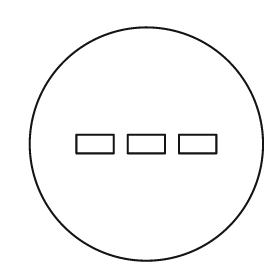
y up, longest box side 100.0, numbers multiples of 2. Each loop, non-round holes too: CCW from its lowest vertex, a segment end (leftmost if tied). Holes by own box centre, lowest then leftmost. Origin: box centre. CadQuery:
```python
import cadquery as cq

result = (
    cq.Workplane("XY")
    .moveTo(0.0, 0.0)
    .circle(50.0)
    .moveTo(-30.0, -4.0)
    .lineTo(-14.0, -4.0)
    .lineTo(-14.0, 4.0)
    .lineTo(-30.0, 4.0)
    .close()
    .moveTo(-8.0, -4.0)
    .lineTo(8.0, -4.0)
    .lineTo(8.0, 4.0)
    .lineTo(-8.0, 4.0)
    .close()
    .moveTo(14.0, -4.0)
    .lineTo(30.0, -4.0)
    .lineTo(30.0, 4.0)
    .lineTo(14.0, 4.0)
    .close()
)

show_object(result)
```